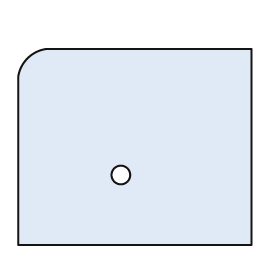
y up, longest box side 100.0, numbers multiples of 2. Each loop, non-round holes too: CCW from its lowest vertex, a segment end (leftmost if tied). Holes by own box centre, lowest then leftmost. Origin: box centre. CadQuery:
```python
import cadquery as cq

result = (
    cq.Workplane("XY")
    .moveTo(-50.0, -42.0)
    .lineTo(50.0, -42.0)
    .lineTo(50.0, 42.0)
    .lineTo(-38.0, 42.0)
    .threePointArc((-46.0, 38.0), (-50.0, 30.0))
    .close()
    .moveTo(-6.0, -12.0)
    .circle(4.0)
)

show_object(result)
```